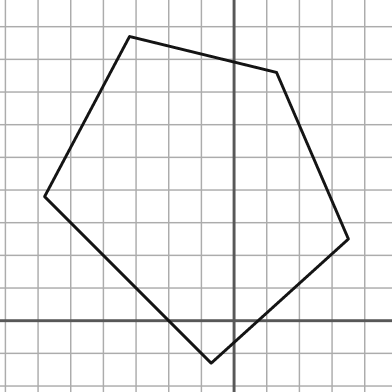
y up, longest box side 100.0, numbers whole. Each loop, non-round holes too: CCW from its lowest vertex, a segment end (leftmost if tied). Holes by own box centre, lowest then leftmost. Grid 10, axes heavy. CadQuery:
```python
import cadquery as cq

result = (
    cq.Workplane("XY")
    .moveTo(-7.0, -13.0)
    .lineTo(35.0, 25.0)
    .lineTo(13.0, 76.0)
    .lineTo(-32.0, 87.0)
    .lineTo(-58.0, 38.0)
    .close()
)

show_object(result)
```